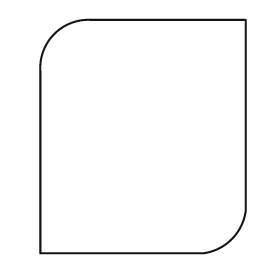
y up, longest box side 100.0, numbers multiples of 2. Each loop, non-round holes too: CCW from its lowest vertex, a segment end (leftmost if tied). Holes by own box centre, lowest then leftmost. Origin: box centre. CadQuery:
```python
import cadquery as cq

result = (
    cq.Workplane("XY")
    .moveTo(-44.0, -50.0)
    .lineTo(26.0, -50.0)
    .threePointArc((38.0, -44.0), (44.0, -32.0))
    .lineTo(44.0, 50.0)
    .lineTo(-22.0, 50.0)
    .threePointArc((-38.0, 44.0), (-44.0, 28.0))
    .close()
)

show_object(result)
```